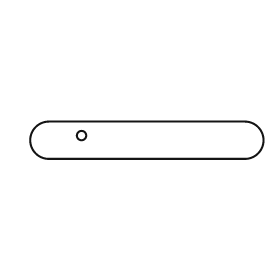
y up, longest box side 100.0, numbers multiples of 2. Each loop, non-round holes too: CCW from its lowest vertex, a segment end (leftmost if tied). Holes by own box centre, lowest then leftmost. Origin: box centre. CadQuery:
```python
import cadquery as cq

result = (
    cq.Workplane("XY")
    .moveTo(-42.0, -8.0)
    .lineTo(42.0, -8.0)
    .threePointArc((50.0, 0.0), (42.0, 8.0))
    .lineTo(-42.0, 8.0)
    .threePointArc((-50.0, 0.0), (-42.0, -8.0))
    .close()
    .moveTo(-28.0, 2.0)
    .circle(2.0)
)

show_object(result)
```